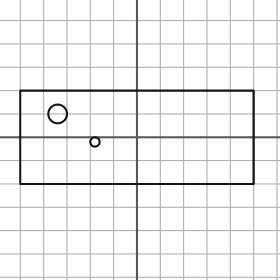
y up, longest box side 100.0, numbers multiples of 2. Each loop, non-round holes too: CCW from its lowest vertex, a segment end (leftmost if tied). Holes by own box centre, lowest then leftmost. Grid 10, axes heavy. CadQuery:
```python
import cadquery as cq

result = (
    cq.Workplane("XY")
    .moveTo(-50.0, -20.0)
    .lineTo(50.0, -20.0)
    .lineTo(50.0, 20.0)
    .lineTo(-50.0, 20.0)
    .close()
    .moveTo(-18.0, -2.0)
    .circle(2.0)
    .moveTo(-34.0, 10.0)
    .circle(4.0)
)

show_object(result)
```